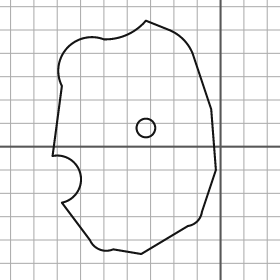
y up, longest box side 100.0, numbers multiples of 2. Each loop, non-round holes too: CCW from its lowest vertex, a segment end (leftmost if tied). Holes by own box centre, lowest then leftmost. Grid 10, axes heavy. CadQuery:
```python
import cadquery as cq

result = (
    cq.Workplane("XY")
    .moveTo(-34.0, -46.0)
    .lineTo(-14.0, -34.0)
    .threePointArc((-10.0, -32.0), (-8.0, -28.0))
    .lineTo(-2.0, -10.0)
    .lineTo(-4.0, 16.0)
    .lineTo(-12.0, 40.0)
    .threePointArc((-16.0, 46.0), (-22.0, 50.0))
    .lineTo(-32.0, 54.0)
    .threePointArc((-40.0, 48.0), (-50.0, 46.0))
    .threePointArc((-66.0, 42.0), (-68.0, 26.0))
    .lineTo(-72.0, -4.0)
    .threePointArc((-60.0, -12.0), (-68.0, -24.0))
    .lineTo(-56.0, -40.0)
    .threePointArc((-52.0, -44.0), (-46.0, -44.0))
    .close()
    .moveTo(-32.0, 8.0)
    .circle(4.0)
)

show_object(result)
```